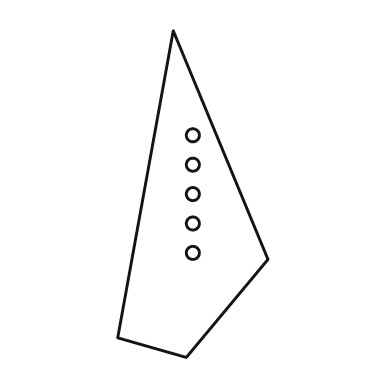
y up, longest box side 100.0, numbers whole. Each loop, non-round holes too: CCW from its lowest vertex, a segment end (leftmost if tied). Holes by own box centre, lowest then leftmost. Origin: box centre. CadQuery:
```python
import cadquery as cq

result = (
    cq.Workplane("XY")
    .moveTo(-2.0, -50.0)
    .lineTo(23.0, -20.0)
    .lineTo(-6.0, 50.0)
    .lineTo(-23.0, -44.0)
    .close()
    .moveTo(0.0, -18.0)
    .circle(2.0)
    .moveTo(0.0, -9.0)
    .circle(2.0)
    .moveTo(0.0, 0.0)
    .circle(2.0)
    .moveTo(0.0, 9.0)
    .circle(2.0)
    .moveTo(0.0, 18.0)
    .circle(2.0)
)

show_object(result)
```